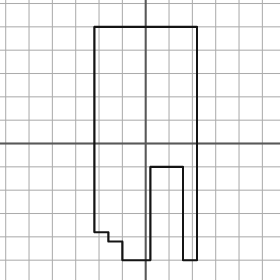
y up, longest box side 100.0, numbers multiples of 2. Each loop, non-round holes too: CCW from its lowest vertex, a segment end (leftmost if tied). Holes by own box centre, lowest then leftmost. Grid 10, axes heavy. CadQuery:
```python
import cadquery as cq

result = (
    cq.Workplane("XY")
    .moveTo(-10.0, -50.0)
    .lineTo(2.0, -50.0)
    .lineTo(2.0, -10.0)
    .lineTo(16.0, -10.0)
    .lineTo(16.0, -50.0)
    .lineTo(22.0, -50.0)
    .lineTo(22.0, 50.0)
    .lineTo(-22.0, 50.0)
    .lineTo(-22.0, -38.0)
    .lineTo(-16.0, -38.0)
    .lineTo(-16.0, -42.0)
    .lineTo(-10.0, -42.0)
    .close()
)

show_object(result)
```